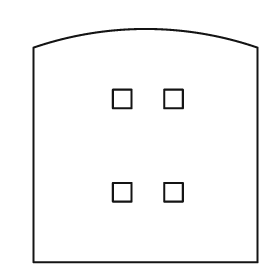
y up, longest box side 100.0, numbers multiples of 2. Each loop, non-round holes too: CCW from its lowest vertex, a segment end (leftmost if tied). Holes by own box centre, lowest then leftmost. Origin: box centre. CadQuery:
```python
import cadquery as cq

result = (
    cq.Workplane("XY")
    .moveTo(-48.0, -50.0)
    .lineTo(48.0, -50.0)
    .lineTo(48.0, 42.0)
    .threePointArc((0.0, 50.0), (-48.0, 42.0))
    .close()
    .moveTo(-14.0, -24.0)
    .lineTo(-6.0, -24.0)
    .lineTo(-6.0, -16.0)
    .lineTo(-14.0, -16.0)
    .close()
    .moveTo(8.0, -24.0)
    .lineTo(16.0, -24.0)
    .lineTo(16.0, -16.0)
    .lineTo(8.0, -16.0)
    .close()
    .moveTo(-14.0, 16.0)
    .lineTo(-6.0, 16.0)
    .lineTo(-6.0, 24.0)
    .lineTo(-14.0, 24.0)
    .close()
    .moveTo(8.0, 16.0)
    .lineTo(16.0, 16.0)
    .lineTo(16.0, 24.0)
    .lineTo(8.0, 24.0)
    .close()
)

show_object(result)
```